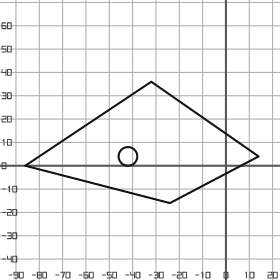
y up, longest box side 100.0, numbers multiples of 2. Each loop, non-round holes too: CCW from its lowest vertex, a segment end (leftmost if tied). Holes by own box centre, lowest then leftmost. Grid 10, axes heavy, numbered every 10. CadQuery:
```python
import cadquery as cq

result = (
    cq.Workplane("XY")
    .moveTo(-24.0, -16.0)
    .lineTo(14.0, 4.0)
    .lineTo(-32.0, 36.0)
    .lineTo(-86.0, 0.0)
    .close()
    .moveTo(-42.0, 4.0)
    .circle(4.0)
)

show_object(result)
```